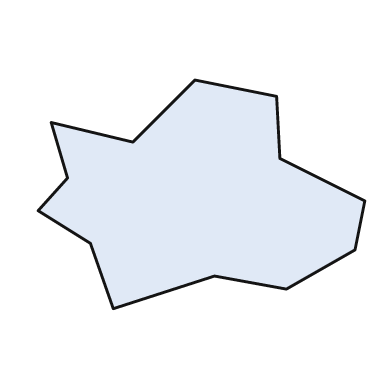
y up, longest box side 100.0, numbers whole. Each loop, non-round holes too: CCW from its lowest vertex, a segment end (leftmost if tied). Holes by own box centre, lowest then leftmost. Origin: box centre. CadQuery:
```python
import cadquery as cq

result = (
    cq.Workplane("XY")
    .moveTo(-27.0, -35.0)
    .lineTo(4.0, -25.0)
    .lineTo(26.0, -29.0)
    .lineTo(47.0, -17.0)
    .lineTo(50.0, -2.0)
    .lineTo(24.0, 11.0)
    .lineTo(23.0, 30.0)
    .lineTo(-2.0, 35.0)
    .lineTo(-21.0, 16.0)
    .lineTo(-46.0, 22.0)
    .lineTo(-41.0, 5.0)
    .lineTo(-50.0, -5.0)
    .lineTo(-34.0, -15.0)
    .close()
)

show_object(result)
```